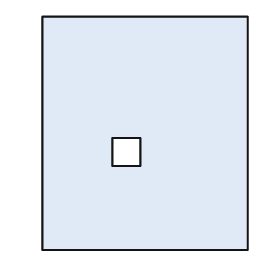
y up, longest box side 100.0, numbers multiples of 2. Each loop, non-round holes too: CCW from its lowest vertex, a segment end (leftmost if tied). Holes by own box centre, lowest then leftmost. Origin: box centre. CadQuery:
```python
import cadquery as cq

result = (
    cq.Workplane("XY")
    .moveTo(-44.0, -50.0)
    .lineTo(44.0, -50.0)
    .lineTo(44.0, 50.0)
    .lineTo(-44.0, 50.0)
    .close()
    .moveTo(-14.0, -14.0)
    .lineTo(-2.0, -14.0)
    .lineTo(-2.0, -2.0)
    .lineTo(-14.0, -2.0)
    .close()
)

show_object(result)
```